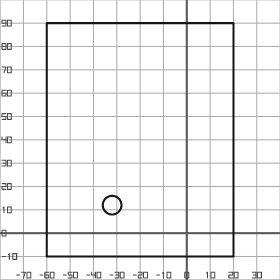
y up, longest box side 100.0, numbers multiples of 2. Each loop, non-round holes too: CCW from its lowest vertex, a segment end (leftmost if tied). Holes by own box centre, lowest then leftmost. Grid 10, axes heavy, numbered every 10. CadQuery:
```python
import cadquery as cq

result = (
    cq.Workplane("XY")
    .moveTo(-60.0, -10.0)
    .lineTo(20.0, -10.0)
    .lineTo(20.0, 90.0)
    .lineTo(-60.0, 90.0)
    .close()
    .moveTo(-32.0, 12.0)
    .circle(4.0)
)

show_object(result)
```